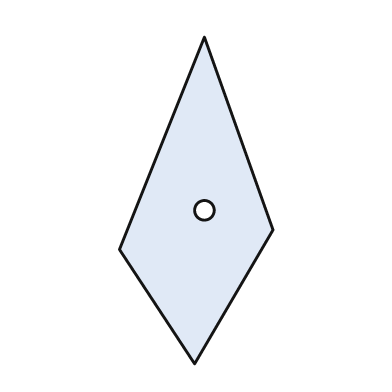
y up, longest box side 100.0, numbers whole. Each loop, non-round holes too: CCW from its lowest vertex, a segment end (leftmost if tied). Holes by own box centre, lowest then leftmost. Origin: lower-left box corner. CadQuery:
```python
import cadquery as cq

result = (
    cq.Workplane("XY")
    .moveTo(23.0, 0.0)
    .lineTo(47.0, 41.0)
    .lineTo(26.0, 100.0)
    .lineTo(0.0, 35.0)
    .close()
    .moveTo(26.0, 47.0)
    .circle(3.0)
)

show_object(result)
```